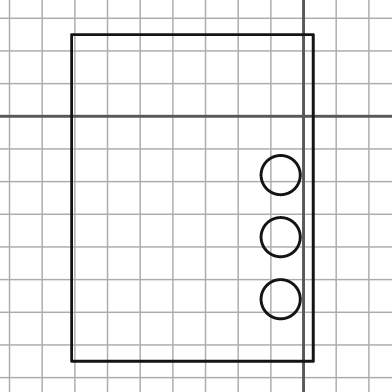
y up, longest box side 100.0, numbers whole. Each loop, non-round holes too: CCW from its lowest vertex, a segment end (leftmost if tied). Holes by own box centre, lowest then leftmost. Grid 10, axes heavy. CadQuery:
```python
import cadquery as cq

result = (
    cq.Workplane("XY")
    .moveTo(-71.0, -75.0)
    .lineTo(3.0, -75.0)
    .lineTo(3.0, 25.0)
    .lineTo(-71.0, 25.0)
    .close()
    .moveTo(-7.0, -56.0)
    .circle(6.0)
    .moveTo(-7.0, -37.0)
    .circle(6.0)
    .moveTo(-7.0, -18.0)
    .circle(6.0)
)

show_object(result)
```